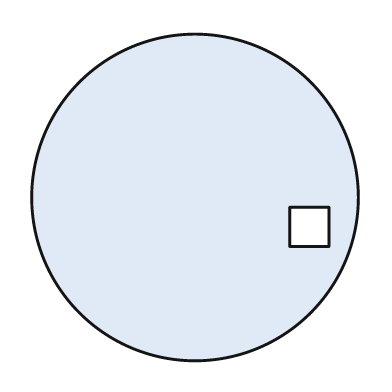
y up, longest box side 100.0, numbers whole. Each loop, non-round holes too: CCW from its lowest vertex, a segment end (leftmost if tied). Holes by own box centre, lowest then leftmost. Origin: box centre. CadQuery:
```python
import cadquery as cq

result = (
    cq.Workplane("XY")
    .moveTo(0.0, 0.0)
    .circle(50.0)
    .moveTo(29.0, -15.0)
    .lineTo(41.0, -15.0)
    .lineTo(41.0, -3.0)
    .lineTo(29.0, -3.0)
    .close()
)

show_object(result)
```